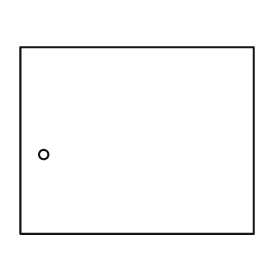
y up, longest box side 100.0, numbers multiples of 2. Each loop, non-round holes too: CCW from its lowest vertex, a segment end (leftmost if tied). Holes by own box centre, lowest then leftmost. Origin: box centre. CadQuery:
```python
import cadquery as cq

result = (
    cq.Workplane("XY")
    .moveTo(-50.0, -40.0)
    .lineTo(50.0, -40.0)
    .lineTo(50.0, 40.0)
    .lineTo(-50.0, 40.0)
    .close()
    .moveTo(-40.0, -6.0)
    .circle(2.0)
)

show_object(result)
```